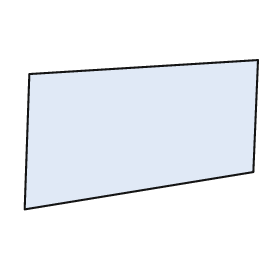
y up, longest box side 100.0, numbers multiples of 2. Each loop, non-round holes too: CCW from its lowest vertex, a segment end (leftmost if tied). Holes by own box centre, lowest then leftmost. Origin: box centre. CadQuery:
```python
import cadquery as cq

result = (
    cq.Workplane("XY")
    .moveTo(-50.0, -32.0)
    .lineTo(48.0, -16.0)
    .lineTo(50.0, 32.0)
    .lineTo(-48.0, 26.0)
    .close()
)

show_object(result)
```